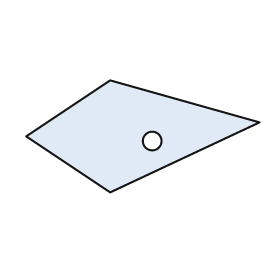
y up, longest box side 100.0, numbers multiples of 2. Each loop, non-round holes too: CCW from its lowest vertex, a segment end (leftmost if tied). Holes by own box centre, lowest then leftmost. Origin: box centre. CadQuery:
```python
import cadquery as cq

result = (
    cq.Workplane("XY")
    .moveTo(-14.0, -24.0)
    .lineTo(50.0, 6.0)
    .lineTo(-14.0, 24.0)
    .lineTo(-50.0, 0.0)
    .close()
    .moveTo(4.0, -2.0)
    .circle(4.0)
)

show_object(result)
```